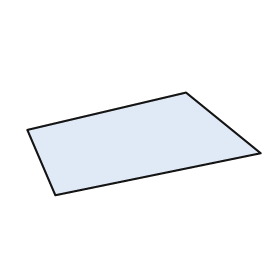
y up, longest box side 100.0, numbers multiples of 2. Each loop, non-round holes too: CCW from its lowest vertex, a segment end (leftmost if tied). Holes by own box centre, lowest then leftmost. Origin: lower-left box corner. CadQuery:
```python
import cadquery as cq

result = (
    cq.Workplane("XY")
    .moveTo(12.0, 0.0)
    .lineTo(100.0, 18.0)
    .lineTo(68.0, 44.0)
    .lineTo(0.0, 28.0)
    .close()
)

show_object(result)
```